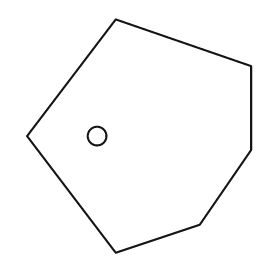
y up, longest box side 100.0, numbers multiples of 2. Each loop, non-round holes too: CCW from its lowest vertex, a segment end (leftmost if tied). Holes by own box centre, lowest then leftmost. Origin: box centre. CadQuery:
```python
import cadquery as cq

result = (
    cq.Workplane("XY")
    .moveTo(-10.0, -50.0)
    .lineTo(26.0, -38.0)
    .lineTo(48.0, -6.0)
    .lineTo(48.0, 30.0)
    .lineTo(-10.0, 50.0)
    .lineTo(-48.0, 0.0)
    .close()
    .moveTo(-18.0, 0.0)
    .circle(4.0)
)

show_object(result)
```